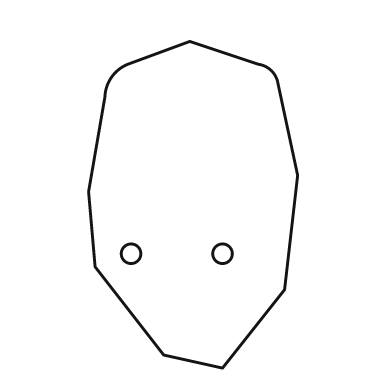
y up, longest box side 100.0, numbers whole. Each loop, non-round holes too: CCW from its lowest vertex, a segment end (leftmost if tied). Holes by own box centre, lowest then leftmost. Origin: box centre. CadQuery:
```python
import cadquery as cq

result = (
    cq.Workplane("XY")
    .moveTo(9.0, -50.0)
    .lineTo(28.0, -26.0)
    .lineTo(32.0, 9.0)
    .lineTo(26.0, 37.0)
    .threePointArc((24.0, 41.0), (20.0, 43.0))
    .lineTo(-1.0, 50.0)
    .lineTo(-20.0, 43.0)
    .threePointArc((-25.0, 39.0), (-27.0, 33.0))
    .lineTo(-32.0, 4.0)
    .lineTo(-30.0, -19.0)
    .lineTo(-9.0, -46.0)
    .close()
    .moveTo(-19.0, -15.0)
    .circle(3.0)
    .moveTo(9.0, -15.0)
    .circle(3.0)
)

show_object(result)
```